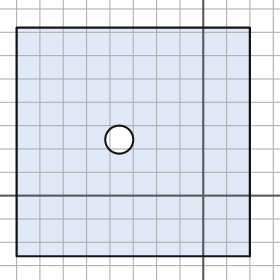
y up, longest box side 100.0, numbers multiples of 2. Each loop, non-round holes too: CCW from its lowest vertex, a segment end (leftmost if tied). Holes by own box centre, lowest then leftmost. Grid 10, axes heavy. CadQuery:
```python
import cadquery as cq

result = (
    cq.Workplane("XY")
    .moveTo(-80.0, -26.0)
    .lineTo(20.0, -26.0)
    .lineTo(20.0, 72.0)
    .lineTo(-80.0, 72.0)
    .close()
    .moveTo(-36.0, 24.0)
    .circle(6.0)
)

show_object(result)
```